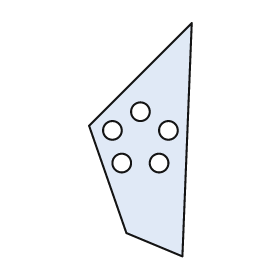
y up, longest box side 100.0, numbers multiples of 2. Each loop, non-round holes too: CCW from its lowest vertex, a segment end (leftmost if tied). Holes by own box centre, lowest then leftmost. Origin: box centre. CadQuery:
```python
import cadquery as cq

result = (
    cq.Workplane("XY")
    .moveTo(18.0, -50.0)
    .lineTo(22.0, 50.0)
    .lineTo(-22.0, 6.0)
    .lineTo(-6.0, -40.0)
    .close()
    .moveTo(-8.0, -10.0)
    .circle(4.0)
    .moveTo(8.0, -10.0)
    .circle(4.0)
    .moveTo(-12.0, 4.0)
    .circle(4.0)
    .moveTo(12.0, 4.0)
    .circle(4.0)
    .moveTo(0.0, 12.0)
    .circle(4.0)
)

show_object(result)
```